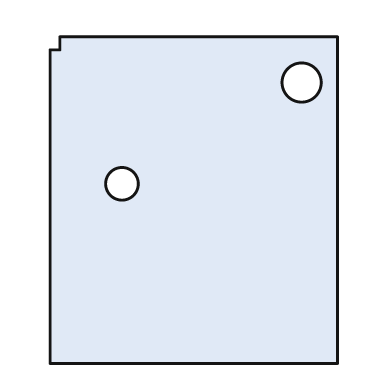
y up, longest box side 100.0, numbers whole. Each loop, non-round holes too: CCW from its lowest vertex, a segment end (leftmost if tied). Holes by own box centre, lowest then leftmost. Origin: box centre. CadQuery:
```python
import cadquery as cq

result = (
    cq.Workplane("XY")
    .moveTo(-44.0, -50.0)
    .lineTo(44.0, -50.0)
    .lineTo(44.0, 50.0)
    .lineTo(-41.0, 50.0)
    .lineTo(-41.0, 46.0)
    .lineTo(-44.0, 46.0)
    .close()
    .moveTo(-22.0, 5.0)
    .circle(5.0)
    .moveTo(33.0, 36.0)
    .circle(6.0)
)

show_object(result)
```